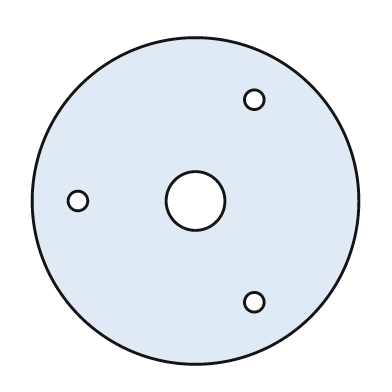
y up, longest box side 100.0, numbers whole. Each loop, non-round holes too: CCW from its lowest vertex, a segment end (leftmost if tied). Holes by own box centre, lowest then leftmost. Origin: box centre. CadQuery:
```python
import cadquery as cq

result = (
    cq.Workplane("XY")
    .moveTo(0.0, 0.0)
    .circle(50.0)
    .moveTo(18.0, -31.0)
    .circle(3.0)
    .moveTo(-36.0, 0.0)
    .circle(3.0)
    .moveTo(0.0, 0.0)
    .circle(9.0)
    .moveTo(18.0, 31.0)
    .circle(3.0)
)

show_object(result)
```